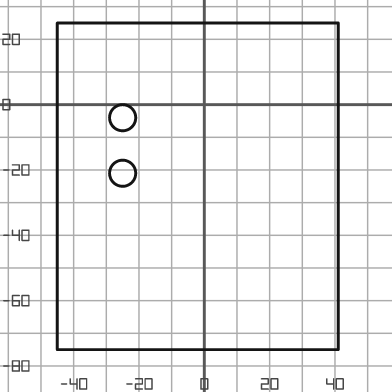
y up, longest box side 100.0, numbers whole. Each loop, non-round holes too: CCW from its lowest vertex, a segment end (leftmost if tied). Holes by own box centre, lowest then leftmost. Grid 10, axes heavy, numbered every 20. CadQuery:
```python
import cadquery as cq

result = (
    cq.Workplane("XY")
    .moveTo(-45.0, -75.0)
    .lineTo(41.0, -75.0)
    .lineTo(41.0, 25.0)
    .lineTo(-45.0, 25.0)
    .close()
    .moveTo(-25.0, -21.0)
    .circle(4.0)
    .moveTo(-25.0, -4.0)
    .circle(4.0)
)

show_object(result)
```